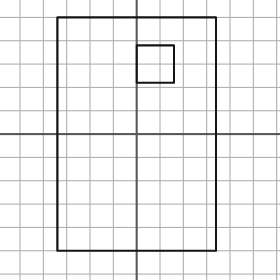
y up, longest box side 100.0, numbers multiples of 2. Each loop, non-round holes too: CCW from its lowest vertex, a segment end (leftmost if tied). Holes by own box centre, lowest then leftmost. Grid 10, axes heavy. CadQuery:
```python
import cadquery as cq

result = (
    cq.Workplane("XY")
    .moveTo(-34.0, -50.0)
    .lineTo(34.0, -50.0)
    .lineTo(34.0, 50.0)
    .lineTo(-34.0, 50.0)
    .close()
    .moveTo(0.0, 22.0)
    .lineTo(16.0, 22.0)
    .lineTo(16.0, 38.0)
    .lineTo(0.0, 38.0)
    .close()
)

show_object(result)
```